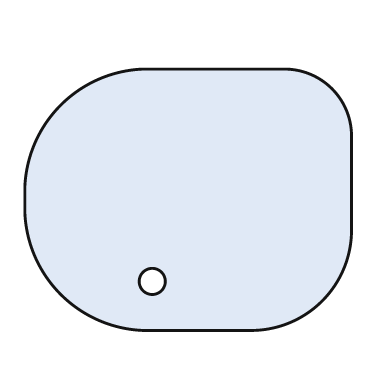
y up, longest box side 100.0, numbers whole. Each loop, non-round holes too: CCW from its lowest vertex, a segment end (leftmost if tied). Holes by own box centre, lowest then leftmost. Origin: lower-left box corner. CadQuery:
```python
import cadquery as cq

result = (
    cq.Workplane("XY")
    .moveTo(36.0, 0.0)
    .lineTo(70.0, 0.0)
    .threePointArc((91.0, 9.0), (100.0, 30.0))
    .lineTo(100.0, 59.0)
    .threePointArc((94.0, 74.0), (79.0, 80.0))
    .lineTo(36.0, 80.0)
    .threePointArc((11.0, 69.0), (0.0, 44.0))
    .lineTo(0.0, 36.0)
    .threePointArc((11.0, 11.0), (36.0, 0.0))
    .close()
    .moveTo(39.0, 15.0)
    .circle(4.0)
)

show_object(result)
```